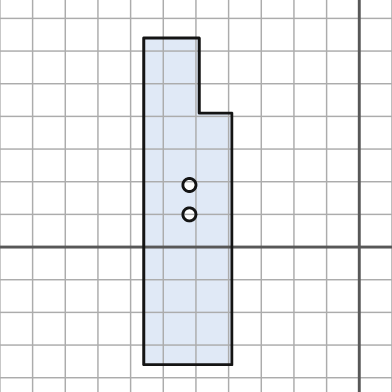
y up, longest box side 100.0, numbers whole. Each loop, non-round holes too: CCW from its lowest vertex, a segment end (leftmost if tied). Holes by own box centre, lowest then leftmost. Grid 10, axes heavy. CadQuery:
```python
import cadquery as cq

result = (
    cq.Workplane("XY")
    .moveTo(-66.0, -36.0)
    .lineTo(-39.0, -36.0)
    .lineTo(-39.0, 41.0)
    .lineTo(-49.0, 41.0)
    .lineTo(-49.0, 64.0)
    .lineTo(-66.0, 64.0)
    .close()
    .moveTo(-52.0, 10.0)
    .circle(2.0)
    .moveTo(-52.0, 19.0)
    .circle(2.0)
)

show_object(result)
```